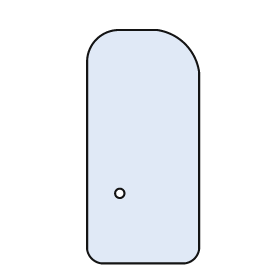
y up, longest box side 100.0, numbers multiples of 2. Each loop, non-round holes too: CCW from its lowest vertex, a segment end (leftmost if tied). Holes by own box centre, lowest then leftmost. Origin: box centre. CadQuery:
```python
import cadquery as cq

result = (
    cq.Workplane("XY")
    .moveTo(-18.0, -50.0)
    .lineTo(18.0, -50.0)
    .threePointArc((22.0, -48.0), (24.0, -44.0))
    .lineTo(24.0, 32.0)
    .threePointArc((18.0, 44.0), (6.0, 50.0))
    .lineTo(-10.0, 50.0)
    .threePointArc((-20.0, 46.0), (-24.0, 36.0))
    .lineTo(-24.0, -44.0)
    .threePointArc((-22.0, -48.0), (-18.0, -50.0))
    .close()
    .moveTo(-10.0, -20.0)
    .circle(2.0)
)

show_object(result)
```